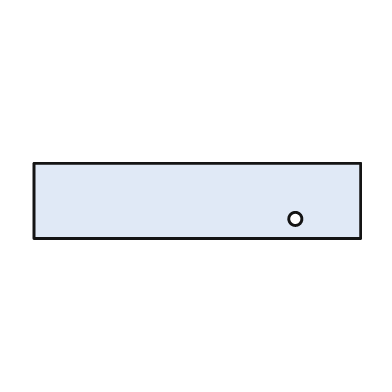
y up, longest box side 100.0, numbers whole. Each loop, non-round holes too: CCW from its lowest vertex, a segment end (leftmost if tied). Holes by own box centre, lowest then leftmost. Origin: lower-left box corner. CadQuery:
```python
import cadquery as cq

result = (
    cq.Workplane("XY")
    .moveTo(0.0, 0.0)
    .lineTo(100.0, 0.0)
    .lineTo(100.0, 23.0)
    .lineTo(0.0, 23.0)
    .close()
    .moveTo(80.0, 6.0)
    .circle(2.0)
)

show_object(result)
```